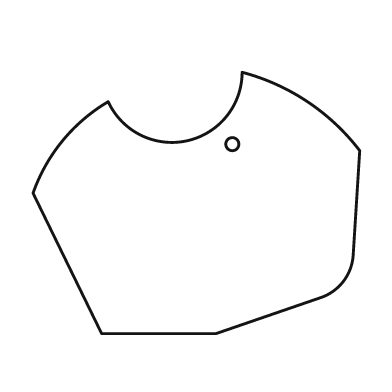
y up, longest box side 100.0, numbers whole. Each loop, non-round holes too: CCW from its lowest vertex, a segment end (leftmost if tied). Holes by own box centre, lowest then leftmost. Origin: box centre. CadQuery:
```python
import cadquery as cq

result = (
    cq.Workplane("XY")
    .moveTo(-29.0, -40.0)
    .lineTo(6.0, -40.0)
    .lineTo(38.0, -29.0)
    .threePointArc((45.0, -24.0), (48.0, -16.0))
    .lineTo(50.0, 16.0)
    .threePointArc((34.0, 31.0), (14.0, 40.0))
    .threePointArc((-3.0, 19.0), (-27.0, 31.0))
    .threePointArc((-41.0, 19.0), (-50.0, 3.0))
    .close()
    .moveTo(11.0, 18.0)
    .circle(2.0)
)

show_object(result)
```